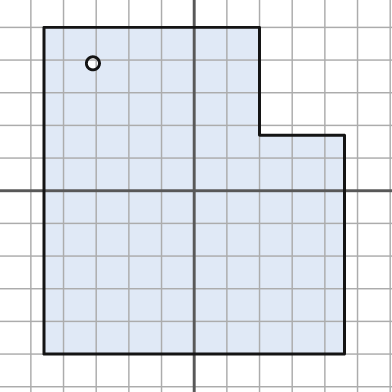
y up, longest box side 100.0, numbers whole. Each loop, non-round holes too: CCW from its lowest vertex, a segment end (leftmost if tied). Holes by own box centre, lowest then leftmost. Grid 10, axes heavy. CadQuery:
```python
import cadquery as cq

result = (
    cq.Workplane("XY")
    .moveTo(-46.0, -50.0)
    .lineTo(46.0, -50.0)
    .lineTo(46.0, 17.0)
    .lineTo(20.0, 17.0)
    .lineTo(20.0, 50.0)
    .lineTo(-46.0, 50.0)
    .close()
    .moveTo(-31.0, 39.0)
    .circle(2.0)
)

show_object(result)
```